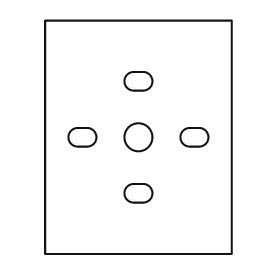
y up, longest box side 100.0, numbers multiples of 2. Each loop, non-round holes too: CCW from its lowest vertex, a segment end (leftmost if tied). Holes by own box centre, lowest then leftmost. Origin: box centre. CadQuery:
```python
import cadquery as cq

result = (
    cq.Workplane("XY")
    .moveTo(-40.0, -50.0)
    .lineTo(40.0, -50.0)
    .lineTo(40.0, 50.0)
    .lineTo(-40.0, 50.0)
    .close()
    .moveTo(-2.0, -28.0)
    .lineTo(2.0, -28.0)
    .threePointArc((6.0, -24.0), (2.0, -20.0))
    .lineTo(-2.0, -20.0)
    .threePointArc((-6.0, -24.0), (-2.0, -28.0))
    .close()
    .moveTo(-26.0, -4.0)
    .lineTo(-22.0, -4.0)
    .threePointArc((-18.0, 0.0), (-22.0, 4.0))
    .lineTo(-26.0, 4.0)
    .threePointArc((-30.0, 0.0), (-26.0, -4.0))
    .close()
    .moveTo(0.0, 0.0)
    .circle(6.0)
    .moveTo(22.0, -4.0)
    .lineTo(26.0, -4.0)
    .threePointArc((30.0, 0.0), (26.0, 4.0))
    .lineTo(22.0, 4.0)
    .threePointArc((18.0, 0.0), (22.0, -4.0))
    .close()
    .moveTo(-2.0, 20.0)
    .lineTo(2.0, 20.0)
    .threePointArc((6.0, 24.0), (2.0, 28.0))
    .lineTo(-2.0, 28.0)
    .threePointArc((-6.0, 24.0), (-2.0, 20.0))
    .close()
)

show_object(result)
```